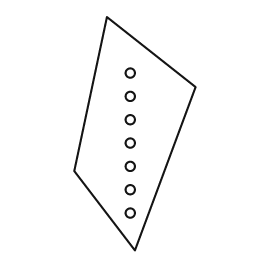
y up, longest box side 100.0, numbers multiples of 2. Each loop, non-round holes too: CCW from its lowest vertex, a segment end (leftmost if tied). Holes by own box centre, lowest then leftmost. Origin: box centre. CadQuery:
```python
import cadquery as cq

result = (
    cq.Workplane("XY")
    .moveTo(0.0, -50.0)
    .lineTo(26.0, 20.0)
    .lineTo(-12.0, 50.0)
    .lineTo(-26.0, -16.0)
    .close()
    .moveTo(-2.0, -34.0)
    .circle(2.0)
    .moveTo(-2.0, -24.0)
    .circle(2.0)
    .moveTo(-2.0, -14.0)
    .circle(2.0)
    .moveTo(-2.0, -4.0)
    .circle(2.0)
    .moveTo(-2.0, 6.0)
    .circle(2.0)
    .moveTo(-2.0, 16.0)
    .circle(2.0)
    .moveTo(-2.0, 26.0)
    .circle(2.0)
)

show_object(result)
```